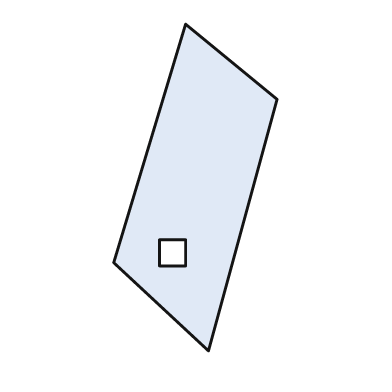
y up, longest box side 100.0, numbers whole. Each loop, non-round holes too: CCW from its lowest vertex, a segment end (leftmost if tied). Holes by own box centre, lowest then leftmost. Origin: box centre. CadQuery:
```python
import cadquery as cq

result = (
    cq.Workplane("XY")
    .moveTo(4.0, -50.0)
    .lineTo(25.0, 27.0)
    .lineTo(-3.0, 50.0)
    .lineTo(-25.0, -23.0)
    .close()
    .moveTo(-11.0, -24.0)
    .lineTo(-3.0, -24.0)
    .lineTo(-3.0, -16.0)
    .lineTo(-11.0, -16.0)
    .close()
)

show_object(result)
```